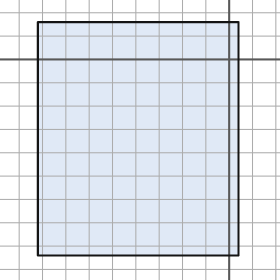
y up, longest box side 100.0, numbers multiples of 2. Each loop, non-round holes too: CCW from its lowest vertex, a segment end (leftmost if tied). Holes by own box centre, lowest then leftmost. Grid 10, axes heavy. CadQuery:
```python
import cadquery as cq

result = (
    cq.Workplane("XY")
    .moveTo(-82.0, -84.0)
    .lineTo(4.0, -84.0)
    .lineTo(4.0, 16.0)
    .lineTo(-82.0, 16.0)
    .close()
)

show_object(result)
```